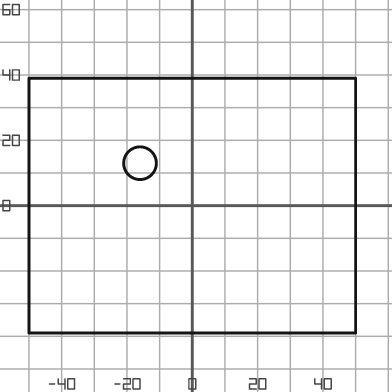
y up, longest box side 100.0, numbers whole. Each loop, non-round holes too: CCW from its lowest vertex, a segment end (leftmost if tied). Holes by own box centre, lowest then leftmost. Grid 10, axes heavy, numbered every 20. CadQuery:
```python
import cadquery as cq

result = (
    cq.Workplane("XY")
    .moveTo(-50.0, -39.0)
    .lineTo(50.0, -39.0)
    .lineTo(50.0, 39.0)
    .lineTo(-50.0, 39.0)
    .close()
    .moveTo(-16.0, 13.0)
    .circle(5.0)
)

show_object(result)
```